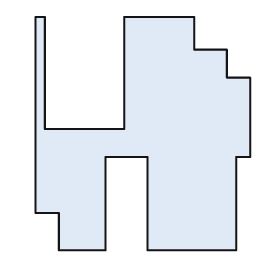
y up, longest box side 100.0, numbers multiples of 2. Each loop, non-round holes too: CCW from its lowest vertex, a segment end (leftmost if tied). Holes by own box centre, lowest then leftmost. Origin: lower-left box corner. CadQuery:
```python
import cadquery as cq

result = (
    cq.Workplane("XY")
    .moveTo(10.0, 0.0)
    .lineTo(30.0, 0.0)
    .lineTo(30.0, 40.0)
    .lineTo(48.0, 40.0)
    .lineTo(48.0, 0.0)
    .lineTo(86.0, 0.0)
    .lineTo(86.0, 40.0)
    .lineTo(92.0, 40.0)
    .lineTo(92.0, 74.0)
    .lineTo(82.0, 74.0)
    .lineTo(82.0, 86.0)
    .lineTo(68.0, 86.0)
    .lineTo(68.0, 100.0)
    .lineTo(38.0, 100.0)
    .lineTo(38.0, 52.0)
    .lineTo(4.0, 52.0)
    .lineTo(4.0, 100.0)
    .lineTo(0.0, 100.0)
    .lineTo(0.0, 16.0)
    .lineTo(10.0, 16.0)
    .close()
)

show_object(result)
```